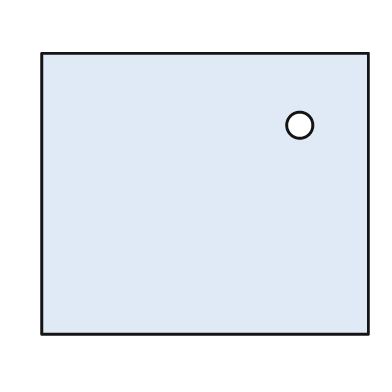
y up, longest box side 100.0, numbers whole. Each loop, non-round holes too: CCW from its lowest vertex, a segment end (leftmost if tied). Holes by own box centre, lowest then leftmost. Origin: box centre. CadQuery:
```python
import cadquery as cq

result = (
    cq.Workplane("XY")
    .moveTo(-50.0, -43.0)
    .lineTo(50.0, -43.0)
    .lineTo(50.0, 43.0)
    .lineTo(-50.0, 43.0)
    .close()
    .moveTo(29.0, 21.0)
    .circle(4.0)
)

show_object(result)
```